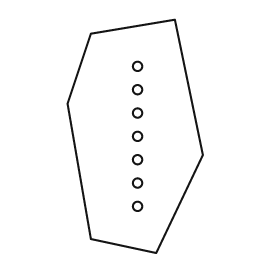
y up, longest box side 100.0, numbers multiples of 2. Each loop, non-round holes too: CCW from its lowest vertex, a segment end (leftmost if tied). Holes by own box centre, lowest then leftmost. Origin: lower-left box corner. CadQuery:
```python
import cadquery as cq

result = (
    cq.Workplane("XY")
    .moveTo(38.0, 0.0)
    .lineTo(58.0, 42.0)
    .lineTo(46.0, 100.0)
    .lineTo(10.0, 94.0)
    .lineTo(0.0, 64.0)
    .lineTo(10.0, 6.0)
    .close()
    .moveTo(30.0, 20.0)
    .circle(2.0)
    .moveTo(30.0, 30.0)
    .circle(2.0)
    .moveTo(30.0, 40.0)
    .circle(2.0)
    .moveTo(30.0, 50.0)
    .circle(2.0)
    .moveTo(30.0, 60.0)
    .circle(2.0)
    .moveTo(30.0, 70.0)
    .circle(2.0)
    .moveTo(30.0, 80.0)
    .circle(2.0)
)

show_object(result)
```